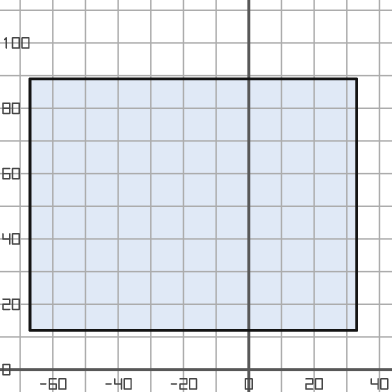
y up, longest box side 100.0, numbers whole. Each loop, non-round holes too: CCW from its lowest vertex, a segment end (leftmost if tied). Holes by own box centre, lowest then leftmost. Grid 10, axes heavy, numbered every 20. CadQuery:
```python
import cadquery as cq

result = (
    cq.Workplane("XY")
    .moveTo(-67.0, 12.0)
    .lineTo(33.0, 12.0)
    .lineTo(33.0, 89.0)
    .lineTo(-67.0, 89.0)
    .close()
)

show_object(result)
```